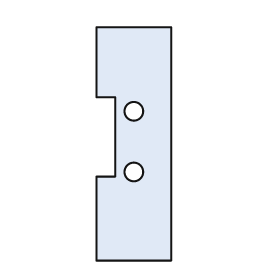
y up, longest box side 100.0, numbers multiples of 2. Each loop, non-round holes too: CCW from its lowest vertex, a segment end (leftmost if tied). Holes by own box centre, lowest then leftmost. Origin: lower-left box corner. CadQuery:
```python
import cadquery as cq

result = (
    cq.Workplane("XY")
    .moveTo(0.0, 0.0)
    .lineTo(32.0, 0.0)
    .lineTo(32.0, 100.0)
    .lineTo(0.0, 100.0)
    .lineTo(0.0, 70.0)
    .lineTo(8.0, 70.0)
    .lineTo(8.0, 36.0)
    .lineTo(0.0, 36.0)
    .close()
    .moveTo(16.0, 38.0)
    .circle(4.0)
    .moveTo(16.0, 64.0)
    .circle(4.0)
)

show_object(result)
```